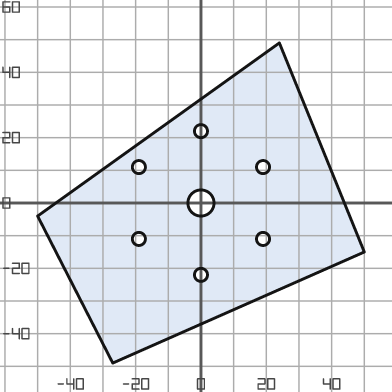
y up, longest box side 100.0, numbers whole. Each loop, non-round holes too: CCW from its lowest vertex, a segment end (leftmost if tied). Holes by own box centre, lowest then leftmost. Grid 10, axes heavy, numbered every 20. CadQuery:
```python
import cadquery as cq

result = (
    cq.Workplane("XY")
    .moveTo(-27.0, -49.0)
    .lineTo(50.0, -15.0)
    .lineTo(24.0, 49.0)
    .lineTo(-50.0, -4.0)
    .close()
    .moveTo(0.0, -22.0)
    .circle(2.0)
    .moveTo(-19.0, -11.0)
    .circle(2.0)
    .moveTo(19.0, -11.0)
    .circle(2.0)
    .moveTo(0.0, 0.0)
    .circle(4.0)
    .moveTo(-19.0, 11.0)
    .circle(2.0)
    .moveTo(19.0, 11.0)
    .circle(2.0)
    .moveTo(0.0, 22.0)
    .circle(2.0)
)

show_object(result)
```